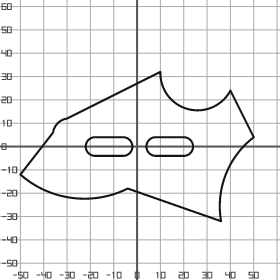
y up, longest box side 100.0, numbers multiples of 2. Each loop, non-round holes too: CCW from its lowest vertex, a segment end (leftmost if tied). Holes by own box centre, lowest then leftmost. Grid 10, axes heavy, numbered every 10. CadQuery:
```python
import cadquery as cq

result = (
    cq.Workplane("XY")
    .moveTo(36.0, -32.0)
    .threePointArc((38.0, -12.0), (50.0, 4.0))
    .lineTo(40.0, 24.0)
    .threePointArc((22.0, 16.0), (10.0, 32.0))
    .lineTo(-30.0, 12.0)
    .threePointArc((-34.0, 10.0), (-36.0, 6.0))
    .lineTo(-50.0, -12.0)
    .threePointArc((-28.0, -22.0), (-4.0, -18.0))
    .close()
    .moveTo(-18.0, -4.0)
    .lineTo(-6.0, -4.0)
    .threePointArc((-2.0, 0.0), (-6.0, 4.0))
    .lineTo(-18.0, 4.0)
    .threePointArc((-22.0, 0.0), (-18.0, -4.0))
    .close()
    .moveTo(8.0, -4.0)
    .lineTo(20.0, -4.0)
    .threePointArc((24.0, 0.0), (20.0, 4.0))
    .lineTo(8.0, 4.0)
    .threePointArc((4.0, 0.0), (8.0, -4.0))
    .close()
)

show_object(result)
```